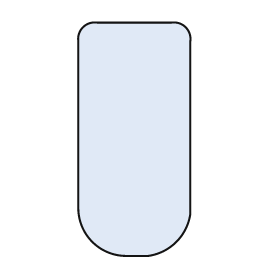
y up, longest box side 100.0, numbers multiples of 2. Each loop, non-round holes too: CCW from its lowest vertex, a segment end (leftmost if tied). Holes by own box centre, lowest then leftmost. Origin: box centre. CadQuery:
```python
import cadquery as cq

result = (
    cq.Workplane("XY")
    .moveTo(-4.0, -50.0)
    .lineTo(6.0, -50.0)
    .threePointArc((18.0, -44.0), (24.0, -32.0))
    .lineTo(24.0, 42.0)
    .threePointArc((22.0, 48.0), (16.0, 50.0))
    .lineTo(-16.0, 50.0)
    .threePointArc((-22.0, 48.0), (-24.0, 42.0))
    .lineTo(-24.0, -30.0)
    .threePointArc((-18.0, -44.0), (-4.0, -50.0))
    .close()
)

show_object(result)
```